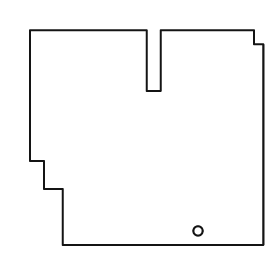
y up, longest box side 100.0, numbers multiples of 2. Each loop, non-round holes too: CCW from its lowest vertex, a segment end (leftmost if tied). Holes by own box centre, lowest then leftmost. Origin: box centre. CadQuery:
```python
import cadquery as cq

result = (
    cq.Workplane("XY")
    .moveTo(-36.0, -46.0)
    .lineTo(50.0, -46.0)
    .lineTo(50.0, 40.0)
    .lineTo(46.0, 40.0)
    .lineTo(46.0, 46.0)
    .lineTo(6.0, 46.0)
    .lineTo(6.0, 20.0)
    .lineTo(0.0, 20.0)
    .lineTo(0.0, 46.0)
    .lineTo(-50.0, 46.0)
    .lineTo(-50.0, -10.0)
    .lineTo(-44.0, -10.0)
    .lineTo(-44.0, -22.0)
    .lineTo(-36.0, -22.0)
    .close()
    .moveTo(22.0, -40.0)
    .circle(2.0)
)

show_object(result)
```